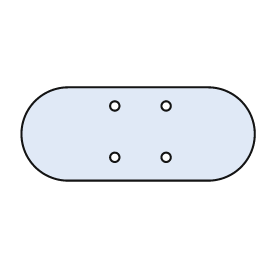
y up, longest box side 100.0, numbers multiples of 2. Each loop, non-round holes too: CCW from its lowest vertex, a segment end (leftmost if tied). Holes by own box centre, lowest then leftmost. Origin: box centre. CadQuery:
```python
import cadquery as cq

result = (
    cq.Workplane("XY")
    .moveTo(-30.0, -20.0)
    .lineTo(30.0, -20.0)
    .threePointArc((50.0, 0.0), (30.0, 20.0))
    .lineTo(-30.0, 20.0)
    .threePointArc((-50.0, 0.0), (-30.0, -20.0))
    .close()
    .moveTo(-10.0, -10.0)
    .circle(2.0)
    .moveTo(12.0, -10.0)
    .circle(2.0)
    .moveTo(-10.0, 12.0)
    .circle(2.0)
    .moveTo(12.0, 12.0)
    .circle(2.0)
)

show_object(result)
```